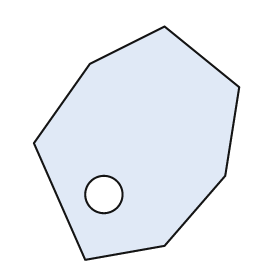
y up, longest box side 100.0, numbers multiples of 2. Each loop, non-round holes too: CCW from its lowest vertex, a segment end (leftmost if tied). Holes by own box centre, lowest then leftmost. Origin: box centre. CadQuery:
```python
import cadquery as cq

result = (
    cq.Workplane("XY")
    .moveTo(-22.0, -50.0)
    .lineTo(12.0, -44.0)
    .lineTo(38.0, -14.0)
    .lineTo(44.0, 24.0)
    .lineTo(12.0, 50.0)
    .lineTo(-20.0, 34.0)
    .lineTo(-44.0, 0.0)
    .close()
    .moveTo(-14.0, -22.0)
    .circle(8.0)
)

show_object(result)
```